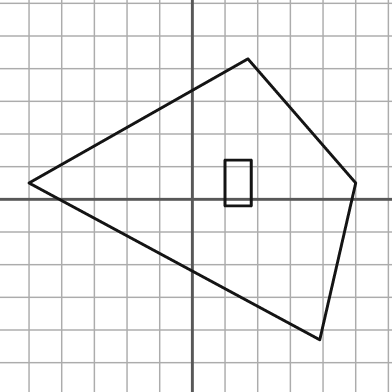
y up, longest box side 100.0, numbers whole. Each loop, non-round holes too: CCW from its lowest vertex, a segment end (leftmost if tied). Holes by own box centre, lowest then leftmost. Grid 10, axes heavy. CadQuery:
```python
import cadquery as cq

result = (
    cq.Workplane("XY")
    .moveTo(39.0, -43.0)
    .lineTo(50.0, 5.0)
    .lineTo(17.0, 43.0)
    .lineTo(-50.0, 5.0)
    .close()
    .moveTo(10.0, -2.0)
    .lineTo(18.0, -2.0)
    .lineTo(18.0, 12.0)
    .lineTo(10.0, 12.0)
    .close()
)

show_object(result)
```